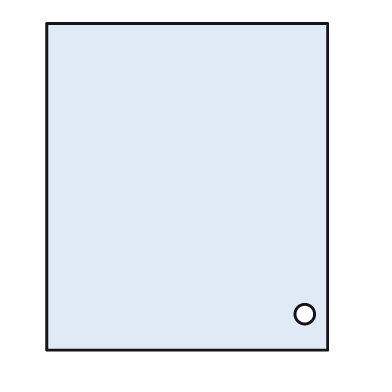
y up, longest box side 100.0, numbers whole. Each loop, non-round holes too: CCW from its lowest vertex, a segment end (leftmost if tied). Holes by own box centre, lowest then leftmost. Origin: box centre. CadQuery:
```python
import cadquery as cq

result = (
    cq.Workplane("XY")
    .moveTo(-43.0, -50.0)
    .lineTo(43.0, -50.0)
    .lineTo(43.0, 50.0)
    .lineTo(-43.0, 50.0)
    .close()
    .moveTo(36.0, -39.0)
    .circle(3.0)
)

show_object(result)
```